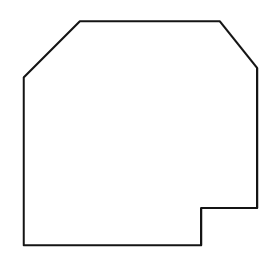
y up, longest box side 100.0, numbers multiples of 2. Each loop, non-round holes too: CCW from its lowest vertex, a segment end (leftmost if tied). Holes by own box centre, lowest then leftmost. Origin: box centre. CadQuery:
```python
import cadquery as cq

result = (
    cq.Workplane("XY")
    .moveTo(-50.0, -48.0)
    .lineTo(26.0, -48.0)
    .lineTo(26.0, -32.0)
    .lineTo(50.0, -32.0)
    .lineTo(50.0, 28.0)
    .lineTo(34.0, 48.0)
    .lineTo(-26.0, 48.0)
    .lineTo(-50.0, 24.0)
    .close()
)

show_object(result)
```